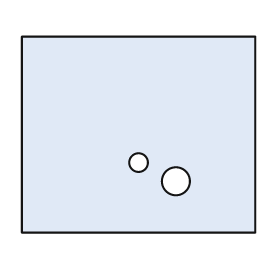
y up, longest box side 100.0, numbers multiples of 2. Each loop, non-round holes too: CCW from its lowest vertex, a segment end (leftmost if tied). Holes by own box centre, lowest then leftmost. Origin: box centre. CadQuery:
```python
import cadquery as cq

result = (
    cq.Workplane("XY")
    .moveTo(-50.0, -42.0)
    .lineTo(50.0, -42.0)
    .lineTo(50.0, 42.0)
    .lineTo(-50.0, 42.0)
    .close()
    .moveTo(16.0, -20.0)
    .circle(6.0)
    .moveTo(0.0, -12.0)
    .circle(4.0)
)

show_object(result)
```